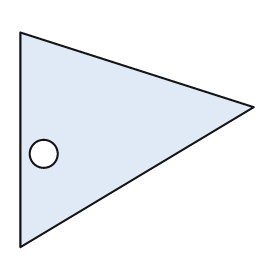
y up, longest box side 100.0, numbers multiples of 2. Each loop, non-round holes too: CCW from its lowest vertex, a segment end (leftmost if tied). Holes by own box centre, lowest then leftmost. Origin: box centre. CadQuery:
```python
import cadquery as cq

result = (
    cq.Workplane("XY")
    .moveTo(-50.0, -46.0)
    .lineTo(50.0, 14.0)
    .lineTo(-50.0, 46.0)
    .close()
    .moveTo(-40.0, -6.0)
    .circle(6.0)
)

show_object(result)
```